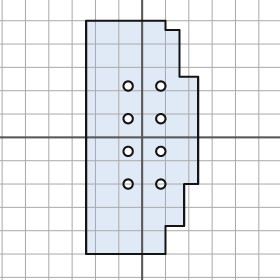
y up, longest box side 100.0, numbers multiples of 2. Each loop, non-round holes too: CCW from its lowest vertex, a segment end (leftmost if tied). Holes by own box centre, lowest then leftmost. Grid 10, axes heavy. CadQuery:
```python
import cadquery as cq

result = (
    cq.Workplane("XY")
    .moveTo(-24.0, -50.0)
    .lineTo(10.0, -50.0)
    .lineTo(10.0, -38.0)
    .lineTo(18.0, -38.0)
    .lineTo(18.0, -20.0)
    .lineTo(24.0, -20.0)
    .lineTo(24.0, 26.0)
    .lineTo(16.0, 26.0)
    .lineTo(16.0, 46.0)
    .lineTo(10.0, 46.0)
    .lineTo(10.0, 50.0)
    .lineTo(-24.0, 50.0)
    .close()
    .moveTo(-6.0, -20.0)
    .circle(2.0)
    .moveTo(8.0, -20.0)
    .circle(2.0)
    .moveTo(-6.0, -6.0)
    .circle(2.0)
    .moveTo(8.0, -6.0)
    .circle(2.0)
    .moveTo(-6.0, 8.0)
    .circle(2.0)
    .moveTo(8.0, 8.0)
    .circle(2.0)
    .moveTo(-6.0, 22.0)
    .circle(2.0)
    .moveTo(8.0, 22.0)
    .circle(2.0)
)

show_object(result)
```